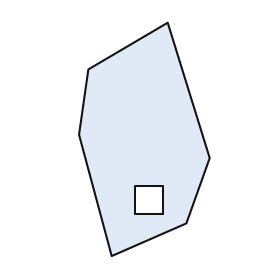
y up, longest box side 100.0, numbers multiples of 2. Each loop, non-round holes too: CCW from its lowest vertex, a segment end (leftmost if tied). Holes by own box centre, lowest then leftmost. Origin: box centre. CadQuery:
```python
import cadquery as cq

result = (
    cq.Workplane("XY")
    .moveTo(-14.0, -50.0)
    .lineTo(18.0, -36.0)
    .lineTo(28.0, -8.0)
    .lineTo(10.0, 50.0)
    .lineTo(-24.0, 30.0)
    .lineTo(-28.0, 2.0)
    .close()
    .moveTo(-4.0, -32.0)
    .lineTo(8.0, -32.0)
    .lineTo(8.0, -20.0)
    .lineTo(-4.0, -20.0)
    .close()
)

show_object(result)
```